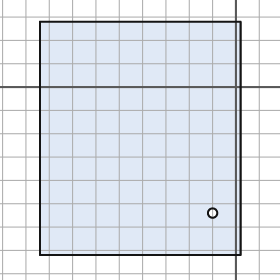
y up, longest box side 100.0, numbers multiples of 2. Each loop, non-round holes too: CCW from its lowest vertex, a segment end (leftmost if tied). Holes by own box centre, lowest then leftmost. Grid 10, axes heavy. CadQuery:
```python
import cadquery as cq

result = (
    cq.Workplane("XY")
    .moveTo(-84.0, -72.0)
    .lineTo(2.0, -72.0)
    .lineTo(2.0, 28.0)
    .lineTo(-84.0, 28.0)
    .close()
    .moveTo(-10.0, -54.0)
    .circle(2.0)
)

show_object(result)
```